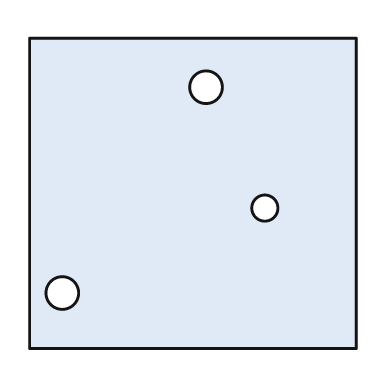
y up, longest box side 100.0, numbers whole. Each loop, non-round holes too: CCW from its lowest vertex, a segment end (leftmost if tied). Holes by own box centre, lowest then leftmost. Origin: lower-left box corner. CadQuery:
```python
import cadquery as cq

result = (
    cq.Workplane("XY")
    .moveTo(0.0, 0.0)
    .lineTo(100.0, 0.0)
    .lineTo(100.0, 95.0)
    .lineTo(0.0, 95.0)
    .close()
    .moveTo(10.0, 17.0)
    .circle(5.0)
    .moveTo(72.0, 43.0)
    .circle(4.0)
    .moveTo(54.0, 80.0)
    .circle(5.0)
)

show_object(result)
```